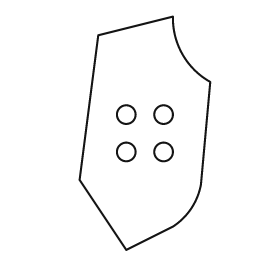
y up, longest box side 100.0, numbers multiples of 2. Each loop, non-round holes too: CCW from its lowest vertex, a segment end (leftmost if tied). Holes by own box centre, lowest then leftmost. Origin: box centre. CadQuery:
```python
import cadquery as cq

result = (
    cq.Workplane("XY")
    .moveTo(-8.0, -50.0)
    .lineTo(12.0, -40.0)
    .threePointArc((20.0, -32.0), (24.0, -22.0))
    .lineTo(28.0, 22.0)
    .threePointArc((16.0, 34.0), (12.0, 50.0))
    .lineTo(-20.0, 42.0)
    .lineTo(-28.0, -20.0)
    .close()
    .moveTo(-8.0, -8.0)
    .circle(4.0)
    .moveTo(8.0, -8.0)
    .circle(4.0)
    .moveTo(-8.0, 8.0)
    .circle(4.0)
    .moveTo(8.0, 8.0)
    .circle(4.0)
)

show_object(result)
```